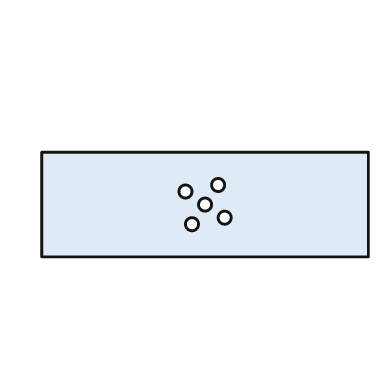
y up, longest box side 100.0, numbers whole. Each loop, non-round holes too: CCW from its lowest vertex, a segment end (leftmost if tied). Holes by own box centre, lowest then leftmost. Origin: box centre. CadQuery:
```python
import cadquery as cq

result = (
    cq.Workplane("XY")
    .moveTo(-50.0, -16.0)
    .lineTo(50.0, -16.0)
    .lineTo(50.0, 16.0)
    .lineTo(-50.0, 16.0)
    .close()
    .moveTo(-4.0, -6.0)
    .circle(2.0)
    .moveTo(6.0, -4.0)
    .circle(2.0)
    .moveTo(0.0, 0.0)
    .circle(2.0)
    .moveTo(-6.0, 4.0)
    .circle(2.0)
    .moveTo(4.0, 6.0)
    .circle(2.0)
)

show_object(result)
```